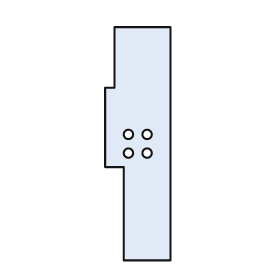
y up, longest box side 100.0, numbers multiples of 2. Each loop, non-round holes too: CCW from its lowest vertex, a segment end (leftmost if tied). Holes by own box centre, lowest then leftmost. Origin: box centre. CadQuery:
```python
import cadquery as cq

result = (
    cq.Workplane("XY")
    .moveTo(-6.0, -50.0)
    .lineTo(14.0, -50.0)
    .lineTo(14.0, 50.0)
    .lineTo(-10.0, 50.0)
    .lineTo(-10.0, 24.0)
    .lineTo(-14.0, 24.0)
    .lineTo(-14.0, -10.0)
    .lineTo(-6.0, -10.0)
    .close()
    .moveTo(-4.0, -4.0)
    .circle(2.0)
    .moveTo(4.0, -4.0)
    .circle(2.0)
    .moveTo(-4.0, 4.0)
    .circle(2.0)
    .moveTo(4.0, 4.0)
    .circle(2.0)
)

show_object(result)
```